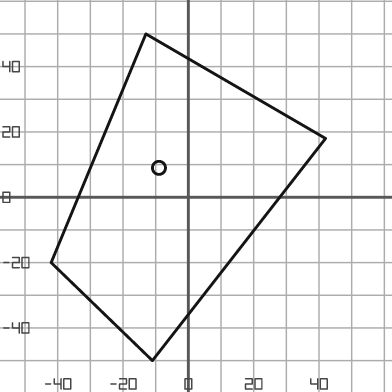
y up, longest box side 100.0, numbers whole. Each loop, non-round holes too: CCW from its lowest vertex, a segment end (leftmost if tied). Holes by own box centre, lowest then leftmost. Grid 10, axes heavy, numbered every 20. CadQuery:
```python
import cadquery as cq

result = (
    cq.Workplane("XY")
    .moveTo(-11.0, -50.0)
    .lineTo(42.0, 18.0)
    .lineTo(-13.0, 50.0)
    .lineTo(-42.0, -20.0)
    .close()
    .moveTo(-9.0, 9.0)
    .circle(2.0)
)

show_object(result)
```